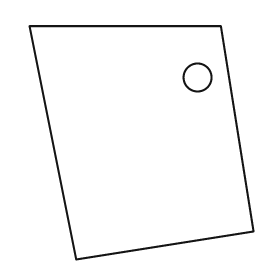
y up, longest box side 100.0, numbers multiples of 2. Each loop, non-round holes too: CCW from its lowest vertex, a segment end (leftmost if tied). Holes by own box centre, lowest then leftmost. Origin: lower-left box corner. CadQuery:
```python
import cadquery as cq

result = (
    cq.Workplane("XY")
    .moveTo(20.0, 0.0)
    .lineTo(96.0, 12.0)
    .lineTo(82.0, 100.0)
    .lineTo(0.0, 100.0)
    .close()
    .moveTo(72.0, 78.0)
    .circle(6.0)
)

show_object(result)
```